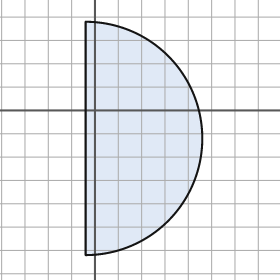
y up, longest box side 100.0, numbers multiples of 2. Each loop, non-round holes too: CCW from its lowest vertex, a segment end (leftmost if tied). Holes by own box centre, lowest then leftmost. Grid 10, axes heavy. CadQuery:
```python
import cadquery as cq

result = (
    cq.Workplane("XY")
    .moveTo(-4.0, -62.0)
    .threePointArc((46.0, -12.0), (-4.0, 38.0))
    .close()
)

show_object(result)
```